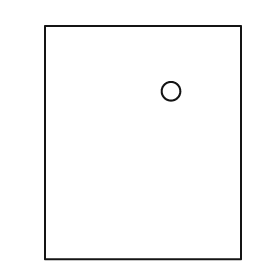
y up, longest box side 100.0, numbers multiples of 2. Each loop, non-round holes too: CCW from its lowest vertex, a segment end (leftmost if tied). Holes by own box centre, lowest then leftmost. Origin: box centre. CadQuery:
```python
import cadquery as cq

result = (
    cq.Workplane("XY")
    .moveTo(-42.0, -50.0)
    .lineTo(42.0, -50.0)
    .lineTo(42.0, 50.0)
    .lineTo(-42.0, 50.0)
    .close()
    .moveTo(12.0, 22.0)
    .circle(4.0)
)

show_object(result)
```